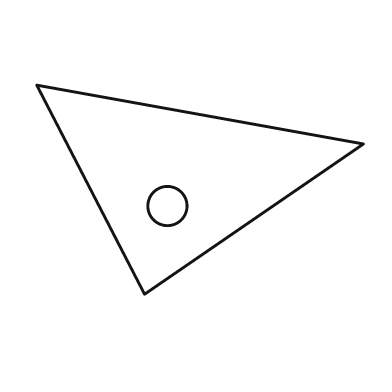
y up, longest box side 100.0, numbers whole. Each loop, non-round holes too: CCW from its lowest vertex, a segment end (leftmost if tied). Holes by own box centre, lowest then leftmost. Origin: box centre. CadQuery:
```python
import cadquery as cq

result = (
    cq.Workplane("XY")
    .moveTo(-17.0, -32.0)
    .lineTo(50.0, 14.0)
    .lineTo(-50.0, 32.0)
    .close()
    .moveTo(-10.0, -5.0)
    .circle(6.0)
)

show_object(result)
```